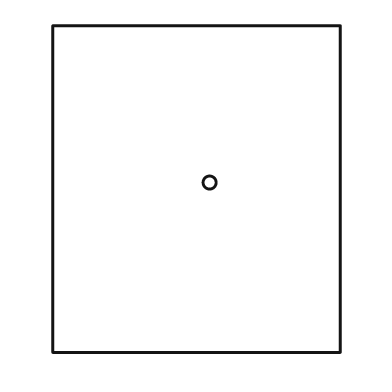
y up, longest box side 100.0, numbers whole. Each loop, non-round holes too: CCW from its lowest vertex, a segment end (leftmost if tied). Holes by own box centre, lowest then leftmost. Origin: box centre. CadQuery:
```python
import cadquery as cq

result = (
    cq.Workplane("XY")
    .moveTo(-44.0, -50.0)
    .lineTo(44.0, -50.0)
    .lineTo(44.0, 50.0)
    .lineTo(-44.0, 50.0)
    .close()
    .moveTo(4.0, 2.0)
    .circle(2.0)
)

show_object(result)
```